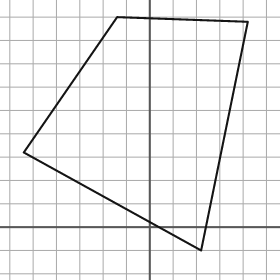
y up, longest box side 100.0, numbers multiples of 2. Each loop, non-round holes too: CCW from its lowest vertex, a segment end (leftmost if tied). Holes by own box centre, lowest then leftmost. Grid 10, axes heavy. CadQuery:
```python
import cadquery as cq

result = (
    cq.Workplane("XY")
    .moveTo(22.0, -10.0)
    .lineTo(42.0, 88.0)
    .lineTo(-14.0, 90.0)
    .lineTo(-54.0, 32.0)
    .close()
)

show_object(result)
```